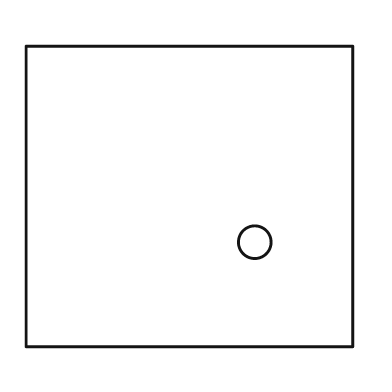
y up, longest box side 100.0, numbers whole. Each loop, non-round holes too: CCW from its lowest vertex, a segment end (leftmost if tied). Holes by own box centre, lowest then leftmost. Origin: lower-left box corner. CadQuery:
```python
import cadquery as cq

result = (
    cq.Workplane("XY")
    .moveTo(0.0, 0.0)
    .lineTo(100.0, 0.0)
    .lineTo(100.0, 92.0)
    .lineTo(0.0, 92.0)
    .close()
    .moveTo(70.0, 32.0)
    .circle(5.0)
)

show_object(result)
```